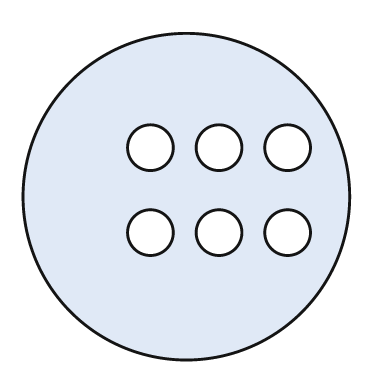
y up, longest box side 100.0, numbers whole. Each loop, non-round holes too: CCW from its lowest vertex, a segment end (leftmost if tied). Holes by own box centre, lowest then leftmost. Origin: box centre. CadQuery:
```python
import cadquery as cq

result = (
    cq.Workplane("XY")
    .moveTo(0.0, 0.0)
    .circle(50.0)
    .moveTo(-11.0, -11.0)
    .circle(7.0)
    .moveTo(10.0, -11.0)
    .circle(7.0)
    .moveTo(31.0, -11.0)
    .circle(7.0)
    .moveTo(-11.0, 15.0)
    .circle(7.0)
    .moveTo(10.0, 15.0)
    .circle(7.0)
    .moveTo(31.0, 15.0)
    .circle(7.0)
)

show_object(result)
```